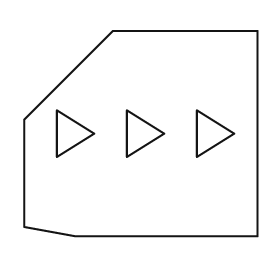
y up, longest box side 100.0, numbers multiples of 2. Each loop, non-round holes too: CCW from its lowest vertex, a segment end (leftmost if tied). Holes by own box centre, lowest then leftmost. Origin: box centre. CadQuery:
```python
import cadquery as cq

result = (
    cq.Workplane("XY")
    .moveTo(-28.0, -44.0)
    .lineTo(50.0, -44.0)
    .lineTo(50.0, 44.0)
    .lineTo(-12.0, 44.0)
    .lineTo(-50.0, 6.0)
    .lineTo(-50.0, -40.0)
    .close()
    .moveTo(-36.0, -10.0)
    .lineTo(-20.0, 0.0)
    .lineTo(-36.0, 10.0)
    .close()
    .moveTo(-6.0, -10.0)
    .lineTo(10.0, 0.0)
    .lineTo(-6.0, 10.0)
    .close()
    .moveTo(24.0, -10.0)
    .lineTo(40.0, 0.0)
    .lineTo(24.0, 10.0)
    .close()
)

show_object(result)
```